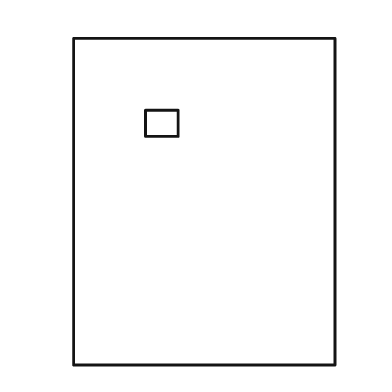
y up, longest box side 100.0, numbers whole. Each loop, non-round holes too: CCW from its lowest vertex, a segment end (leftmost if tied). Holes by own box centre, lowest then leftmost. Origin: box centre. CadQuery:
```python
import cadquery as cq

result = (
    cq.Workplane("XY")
    .moveTo(-40.0, -50.0)
    .lineTo(40.0, -50.0)
    .lineTo(40.0, 50.0)
    .lineTo(-40.0, 50.0)
    .close()
    .moveTo(-18.0, 20.0)
    .lineTo(-8.0, 20.0)
    .lineTo(-8.0, 28.0)
    .lineTo(-18.0, 28.0)
    .close()
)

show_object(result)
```